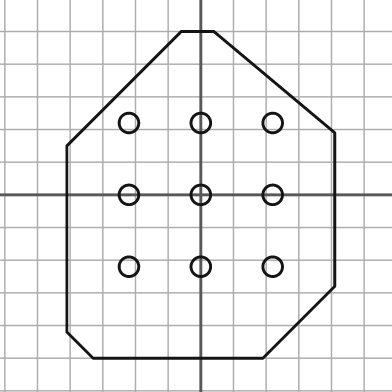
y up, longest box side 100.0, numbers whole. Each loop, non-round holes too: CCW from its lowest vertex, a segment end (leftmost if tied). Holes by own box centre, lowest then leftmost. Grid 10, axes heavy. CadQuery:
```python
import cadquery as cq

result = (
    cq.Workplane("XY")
    .moveTo(-33.0, -50.0)
    .lineTo(19.0, -50.0)
    .lineTo(41.0, -28.0)
    .lineTo(41.0, 19.0)
    .lineTo(4.0, 50.0)
    .lineTo(-6.0, 50.0)
    .lineTo(-41.0, 15.0)
    .lineTo(-41.0, -42.0)
    .close()
    .moveTo(-22.0, -22.0)
    .circle(3.0)
    .moveTo(0.0, -22.0)
    .circle(3.0)
    .moveTo(22.0, -22.0)
    .circle(3.0)
    .moveTo(-22.0, 0.0)
    .circle(3.0)
    .moveTo(0.0, 0.0)
    .circle(3.0)
    .moveTo(22.0, 0.0)
    .circle(3.0)
    .moveTo(-22.0, 22.0)
    .circle(3.0)
    .moveTo(0.0, 22.0)
    .circle(3.0)
    .moveTo(22.0, 22.0)
    .circle(3.0)
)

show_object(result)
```